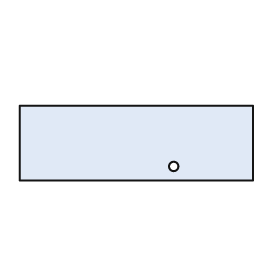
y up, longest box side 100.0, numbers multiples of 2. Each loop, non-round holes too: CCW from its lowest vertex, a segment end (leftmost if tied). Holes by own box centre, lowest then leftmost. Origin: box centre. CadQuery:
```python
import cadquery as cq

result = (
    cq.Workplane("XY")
    .moveTo(-50.0, -16.0)
    .lineTo(50.0, -16.0)
    .lineTo(50.0, 16.0)
    .lineTo(-50.0, 16.0)
    .close()
    .moveTo(16.0, -10.0)
    .circle(2.0)
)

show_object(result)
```